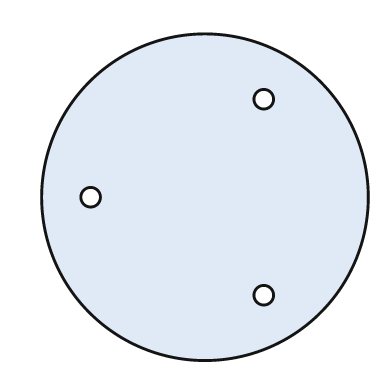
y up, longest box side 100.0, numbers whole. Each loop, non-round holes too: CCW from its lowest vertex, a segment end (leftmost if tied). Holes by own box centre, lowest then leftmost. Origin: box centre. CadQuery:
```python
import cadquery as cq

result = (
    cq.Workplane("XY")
    .moveTo(0.0, 0.0)
    .circle(50.0)
    .moveTo(18.0, -30.0)
    .circle(3.0)
    .moveTo(-35.0, 0.0)
    .circle(3.0)
    .moveTo(18.0, 30.0)
    .circle(3.0)
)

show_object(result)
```